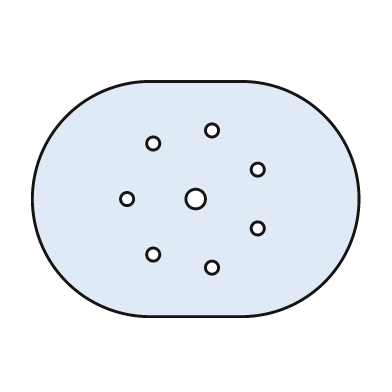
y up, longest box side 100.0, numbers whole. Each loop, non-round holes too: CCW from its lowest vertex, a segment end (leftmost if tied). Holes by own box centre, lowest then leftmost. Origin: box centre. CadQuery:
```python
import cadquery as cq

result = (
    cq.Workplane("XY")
    .moveTo(-14.0, -36.0)
    .lineTo(14.0, -36.0)
    .threePointArc((50.0, 0.0), (14.0, 36.0))
    .lineTo(-14.0, 36.0)
    .threePointArc((-50.0, 0.0), (-14.0, -36.0))
    .close()
    .moveTo(5.0, -21.0)
    .circle(2.0)
    .moveTo(-13.0, -17.0)
    .circle(2.0)
    .moveTo(19.0, -9.0)
    .circle(2.0)
    .moveTo(-21.0, 0.0)
    .circle(2.0)
    .moveTo(0.0, 0.0)
    .circle(3.0)
    .moveTo(19.0, 9.0)
    .circle(2.0)
    .moveTo(-13.0, 17.0)
    .circle(2.0)
    .moveTo(5.0, 21.0)
    .circle(2.0)
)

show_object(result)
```